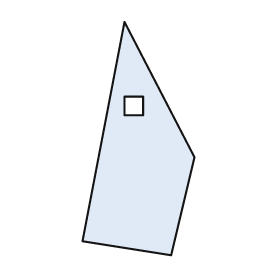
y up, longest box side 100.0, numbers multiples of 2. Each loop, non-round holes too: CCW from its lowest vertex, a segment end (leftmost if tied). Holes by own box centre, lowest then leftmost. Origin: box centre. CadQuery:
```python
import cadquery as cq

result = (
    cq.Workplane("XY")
    .moveTo(14.0, -50.0)
    .lineTo(24.0, -8.0)
    .lineTo(-6.0, 50.0)
    .lineTo(-24.0, -44.0)
    .close()
    .moveTo(-6.0, 10.0)
    .lineTo(2.0, 10.0)
    .lineTo(2.0, 18.0)
    .lineTo(-6.0, 18.0)
    .close()
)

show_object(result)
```